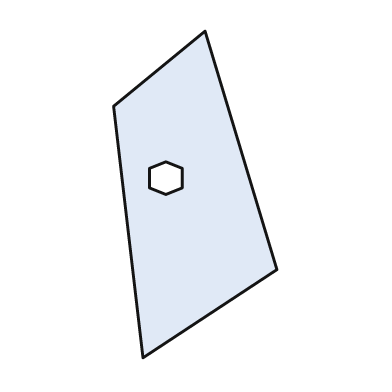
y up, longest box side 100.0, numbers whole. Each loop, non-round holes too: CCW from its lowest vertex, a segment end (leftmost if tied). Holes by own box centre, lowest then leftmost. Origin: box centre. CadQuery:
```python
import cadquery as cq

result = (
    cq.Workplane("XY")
    .moveTo(-16.0, -50.0)
    .lineTo(25.0, -23.0)
    .lineTo(3.0, 50.0)
    .lineTo(-25.0, 27.0)
    .close()
    .moveTo(-9.0, 0.0)
    .lineTo(-4.0, 2.0)
    .lineTo(-4.0, 8.0)
    .lineTo(-9.0, 10.0)
    .lineTo(-14.0, 8.0)
    .lineTo(-14.0, 2.0)
    .close()
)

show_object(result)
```